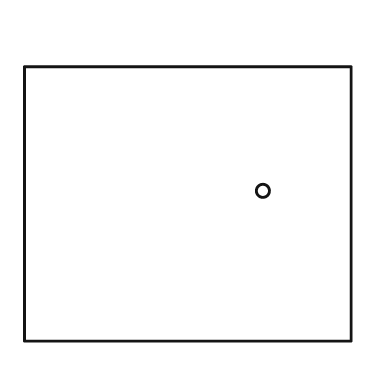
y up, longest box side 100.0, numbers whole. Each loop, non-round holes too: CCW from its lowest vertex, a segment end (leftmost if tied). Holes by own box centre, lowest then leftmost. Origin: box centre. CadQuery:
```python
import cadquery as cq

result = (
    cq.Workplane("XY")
    .moveTo(-50.0, -42.0)
    .lineTo(50.0, -42.0)
    .lineTo(50.0, 42.0)
    .lineTo(-50.0, 42.0)
    .close()
    .moveTo(23.0, 4.0)
    .circle(2.0)
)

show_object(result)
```